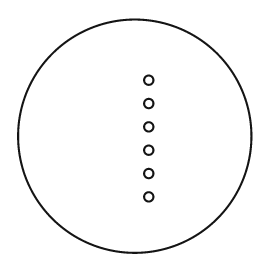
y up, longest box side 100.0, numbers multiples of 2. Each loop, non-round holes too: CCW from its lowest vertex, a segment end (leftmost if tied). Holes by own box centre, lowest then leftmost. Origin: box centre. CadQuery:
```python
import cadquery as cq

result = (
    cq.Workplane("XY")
    .moveTo(0.0, 0.0)
    .circle(50.0)
    .moveTo(6.0, -26.0)
    .circle(2.0)
    .moveTo(6.0, -16.0)
    .circle(2.0)
    .moveTo(6.0, -6.0)
    .circle(2.0)
    .moveTo(6.0, 4.0)
    .circle(2.0)
    .moveTo(6.0, 14.0)
    .circle(2.0)
    .moveTo(6.0, 24.0)
    .circle(2.0)
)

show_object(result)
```